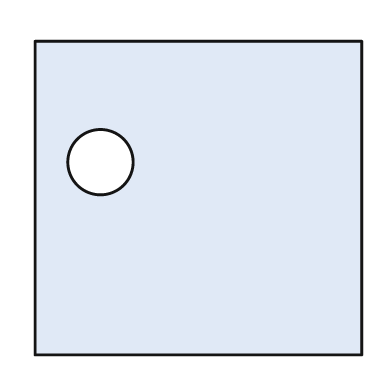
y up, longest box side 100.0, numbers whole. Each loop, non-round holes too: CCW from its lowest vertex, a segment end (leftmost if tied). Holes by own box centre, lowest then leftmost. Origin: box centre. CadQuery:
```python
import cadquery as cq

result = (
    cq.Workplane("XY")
    .moveTo(-50.0, -48.0)
    .lineTo(50.0, -48.0)
    .lineTo(50.0, 48.0)
    .lineTo(-50.0, 48.0)
    .close()
    .moveTo(-30.0, 11.0)
    .circle(10.0)
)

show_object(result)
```